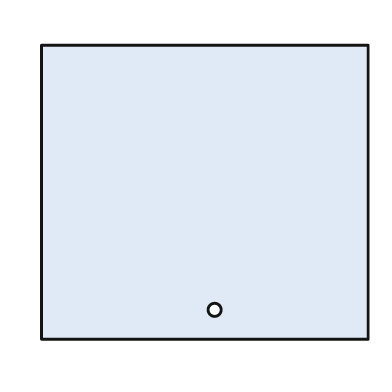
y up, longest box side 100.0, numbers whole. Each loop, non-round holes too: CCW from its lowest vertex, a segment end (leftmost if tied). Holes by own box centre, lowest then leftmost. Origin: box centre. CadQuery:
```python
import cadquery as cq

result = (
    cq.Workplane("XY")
    .moveTo(-50.0, -45.0)
    .lineTo(50.0, -45.0)
    .lineTo(50.0, 45.0)
    .lineTo(-50.0, 45.0)
    .close()
    .moveTo(3.0, -36.0)
    .circle(2.0)
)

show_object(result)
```